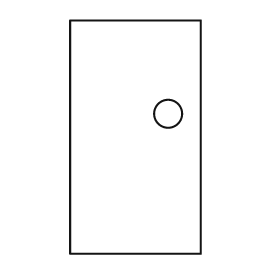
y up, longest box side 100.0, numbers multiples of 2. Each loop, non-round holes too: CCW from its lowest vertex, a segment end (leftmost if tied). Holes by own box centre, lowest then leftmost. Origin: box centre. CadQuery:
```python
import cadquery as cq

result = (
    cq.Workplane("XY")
    .moveTo(-28.0, -50.0)
    .lineTo(28.0, -50.0)
    .lineTo(28.0, 50.0)
    .lineTo(-28.0, 50.0)
    .close()
    .moveTo(14.0, 10.0)
    .circle(6.0)
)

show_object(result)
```